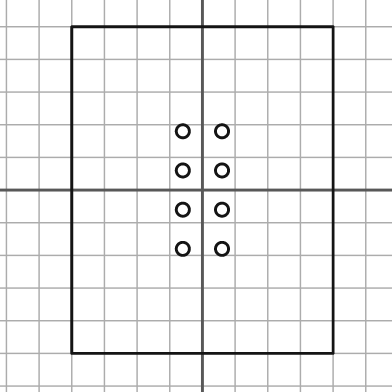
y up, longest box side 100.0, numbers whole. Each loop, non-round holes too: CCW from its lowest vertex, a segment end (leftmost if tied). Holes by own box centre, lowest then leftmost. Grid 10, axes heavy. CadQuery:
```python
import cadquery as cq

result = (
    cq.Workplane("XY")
    .moveTo(-40.0, -50.0)
    .lineTo(40.0, -50.0)
    .lineTo(40.0, 50.0)
    .lineTo(-40.0, 50.0)
    .close()
    .moveTo(-6.0, -18.0)
    .circle(2.0)
    .moveTo(6.0, -18.0)
    .circle(2.0)
    .moveTo(-6.0, -6.0)
    .circle(2.0)
    .moveTo(6.0, -6.0)
    .circle(2.0)
    .moveTo(-6.0, 6.0)
    .circle(2.0)
    .moveTo(6.0, 6.0)
    .circle(2.0)
    .moveTo(-6.0, 18.0)
    .circle(2.0)
    .moveTo(6.0, 18.0)
    .circle(2.0)
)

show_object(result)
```